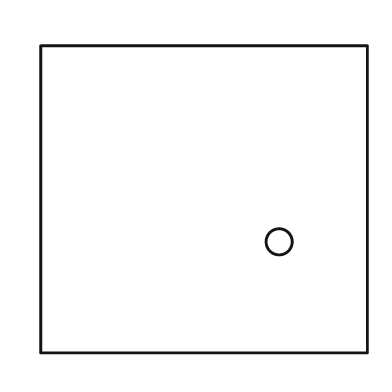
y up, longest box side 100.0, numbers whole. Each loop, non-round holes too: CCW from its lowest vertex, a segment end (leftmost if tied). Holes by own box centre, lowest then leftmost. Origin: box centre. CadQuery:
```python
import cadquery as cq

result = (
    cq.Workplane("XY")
    .moveTo(-50.0, -47.0)
    .lineTo(50.0, -47.0)
    .lineTo(50.0, 47.0)
    .lineTo(-50.0, 47.0)
    .close()
    .moveTo(23.0, -13.0)
    .circle(4.0)
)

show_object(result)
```